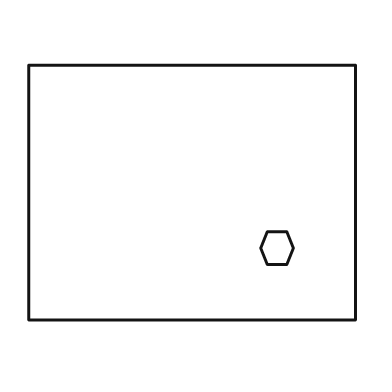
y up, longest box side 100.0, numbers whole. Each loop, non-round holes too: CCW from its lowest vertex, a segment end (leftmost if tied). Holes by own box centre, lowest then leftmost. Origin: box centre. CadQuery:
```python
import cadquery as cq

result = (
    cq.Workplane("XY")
    .moveTo(-50.0, -39.0)
    .lineTo(50.0, -39.0)
    .lineTo(50.0, 39.0)
    .lineTo(-50.0, 39.0)
    .close()
    .moveTo(23.0, -22.0)
    .lineTo(29.0, -22.0)
    .lineTo(31.0, -17.0)
    .lineTo(29.0, -12.0)
    .lineTo(23.0, -12.0)
    .lineTo(21.0, -17.0)
    .close()
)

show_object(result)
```